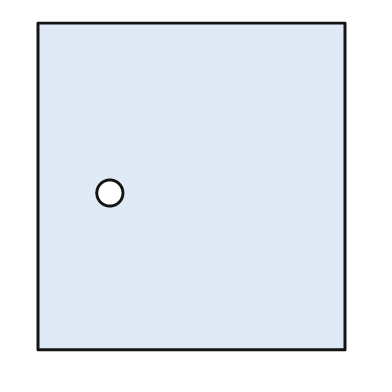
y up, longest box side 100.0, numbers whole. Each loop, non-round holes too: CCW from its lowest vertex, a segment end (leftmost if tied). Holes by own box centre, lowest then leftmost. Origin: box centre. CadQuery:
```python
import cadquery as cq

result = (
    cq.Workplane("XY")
    .moveTo(-47.0, -50.0)
    .lineTo(47.0, -50.0)
    .lineTo(47.0, 50.0)
    .lineTo(-47.0, 50.0)
    .close()
    .moveTo(-25.0, -2.0)
    .circle(4.0)
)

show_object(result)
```